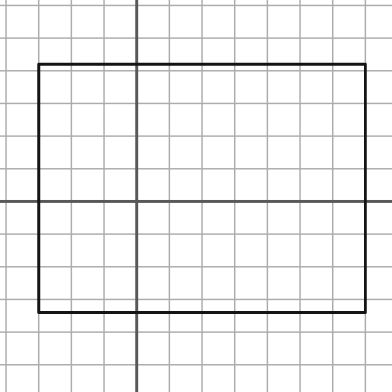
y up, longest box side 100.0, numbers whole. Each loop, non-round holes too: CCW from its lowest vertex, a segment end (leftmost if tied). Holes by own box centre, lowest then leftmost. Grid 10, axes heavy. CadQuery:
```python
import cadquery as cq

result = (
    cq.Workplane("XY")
    .moveTo(-30.0, -34.0)
    .lineTo(70.0, -34.0)
    .lineTo(70.0, 42.0)
    .lineTo(-30.0, 42.0)
    .close()
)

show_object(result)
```